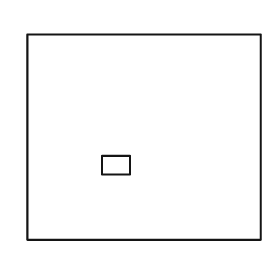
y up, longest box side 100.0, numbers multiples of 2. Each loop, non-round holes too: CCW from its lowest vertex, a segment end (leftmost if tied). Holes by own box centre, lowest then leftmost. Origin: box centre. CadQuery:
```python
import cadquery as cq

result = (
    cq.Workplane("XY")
    .moveTo(-50.0, -44.0)
    .lineTo(50.0, -44.0)
    .lineTo(50.0, 44.0)
    .lineTo(-50.0, 44.0)
    .close()
    .moveTo(-18.0, -16.0)
    .lineTo(-6.0, -16.0)
    .lineTo(-6.0, -8.0)
    .lineTo(-18.0, -8.0)
    .close()
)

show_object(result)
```